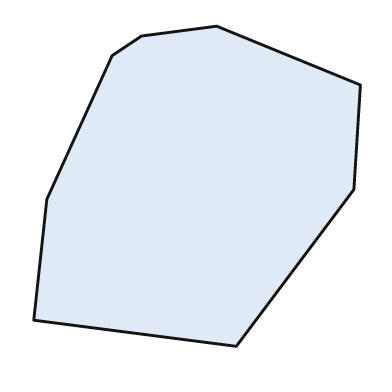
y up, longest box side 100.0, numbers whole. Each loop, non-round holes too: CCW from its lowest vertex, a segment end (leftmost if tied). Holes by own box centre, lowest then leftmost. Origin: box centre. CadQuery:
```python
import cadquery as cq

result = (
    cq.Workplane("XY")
    .moveTo(12.0, -49.0)
    .lineTo(48.0, -1.0)
    .lineTo(50.0, 31.0)
    .lineTo(6.0, 49.0)
    .lineTo(-17.0, 46.0)
    .lineTo(-26.0, 40.0)
    .lineTo(-46.0, -4.0)
    .lineTo(-50.0, -41.0)
    .close()
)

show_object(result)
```